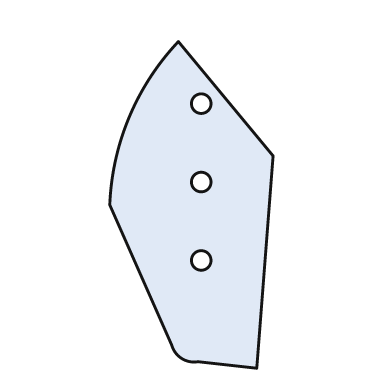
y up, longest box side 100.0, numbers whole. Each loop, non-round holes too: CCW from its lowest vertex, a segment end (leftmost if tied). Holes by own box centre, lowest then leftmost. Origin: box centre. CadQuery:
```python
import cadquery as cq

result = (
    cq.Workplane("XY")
    .moveTo(20.0, -50.0)
    .lineTo(25.0, 15.0)
    .lineTo(-4.0, 50.0)
    .threePointArc((-19.0, 27.0), (-25.0, 0.0))
    .lineTo(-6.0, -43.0)
    .threePointArc((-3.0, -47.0), (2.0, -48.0))
    .close()
    .moveTo(3.0, -17.0)
    .circle(3.0)
    .moveTo(3.0, 7.0)
    .circle(3.0)
    .moveTo(3.0, 31.0)
    .circle(3.0)
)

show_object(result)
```